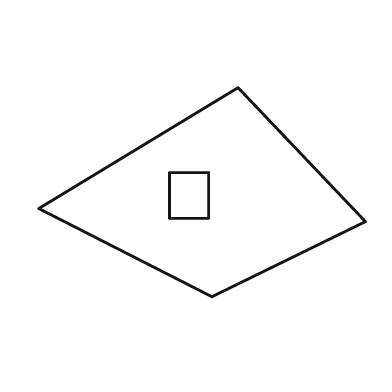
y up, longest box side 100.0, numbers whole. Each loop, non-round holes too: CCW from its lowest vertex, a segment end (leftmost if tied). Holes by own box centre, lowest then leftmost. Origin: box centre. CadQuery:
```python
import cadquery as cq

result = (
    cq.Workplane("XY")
    .moveTo(3.0, -32.0)
    .lineTo(50.0, -9.0)
    .lineTo(11.0, 32.0)
    .lineTo(-50.0, -5.0)
    .close()
    .moveTo(-10.0, -8.0)
    .lineTo(2.0, -8.0)
    .lineTo(2.0, 6.0)
    .lineTo(-10.0, 6.0)
    .close()
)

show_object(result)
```